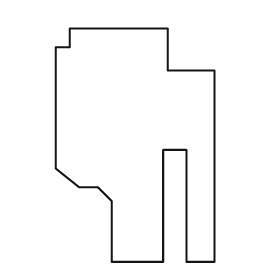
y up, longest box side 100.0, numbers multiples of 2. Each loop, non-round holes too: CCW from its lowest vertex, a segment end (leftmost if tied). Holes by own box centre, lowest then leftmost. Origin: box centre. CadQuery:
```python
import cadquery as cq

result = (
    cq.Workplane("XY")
    .moveTo(-10.0, -50.0)
    .lineTo(12.0, -50.0)
    .lineTo(12.0, -2.0)
    .lineTo(22.0, -2.0)
    .lineTo(22.0, -50.0)
    .lineTo(34.0, -50.0)
    .lineTo(34.0, 32.0)
    .lineTo(14.0, 32.0)
    .lineTo(14.0, 50.0)
    .lineTo(-28.0, 50.0)
    .lineTo(-28.0, 42.0)
    .lineTo(-34.0, 42.0)
    .lineTo(-34.0, -10.0)
    .lineTo(-24.0, -18.0)
    .lineTo(-16.0, -18.0)
    .lineTo(-10.0, -24.0)
    .close()
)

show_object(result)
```